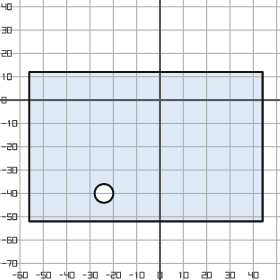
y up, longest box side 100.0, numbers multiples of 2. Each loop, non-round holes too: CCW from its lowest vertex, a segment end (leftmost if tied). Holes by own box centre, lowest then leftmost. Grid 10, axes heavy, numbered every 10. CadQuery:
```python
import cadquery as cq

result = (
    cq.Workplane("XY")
    .moveTo(-56.0, -52.0)
    .lineTo(44.0, -52.0)
    .lineTo(44.0, 12.0)
    .lineTo(-56.0, 12.0)
    .close()
    .moveTo(-24.0, -40.0)
    .circle(4.0)
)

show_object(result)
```